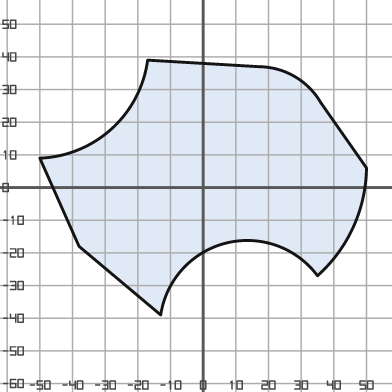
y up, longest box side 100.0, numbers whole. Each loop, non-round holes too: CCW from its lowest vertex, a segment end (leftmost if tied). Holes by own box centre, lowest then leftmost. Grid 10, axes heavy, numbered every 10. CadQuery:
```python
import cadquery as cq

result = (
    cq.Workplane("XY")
    .moveTo(-13.0, -39.0)
    .threePointArc((7.0, -17.0), (35.0, -27.0))
    .threePointArc((46.0, -12.0), (50.0, 6.0))
    .lineTo(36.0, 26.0)
    .threePointArc((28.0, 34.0), (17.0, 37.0))
    .lineTo(-17.0, 39.0)
    .threePointArc((-28.0, 18.0), (-50.0, 9.0))
    .lineTo(-38.0, -18.0)
    .close()
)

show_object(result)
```